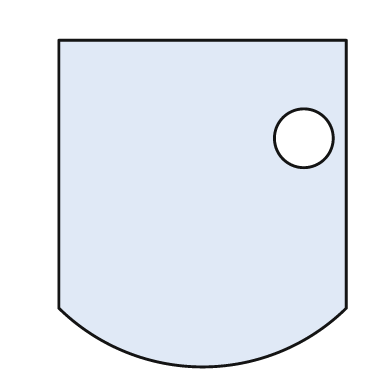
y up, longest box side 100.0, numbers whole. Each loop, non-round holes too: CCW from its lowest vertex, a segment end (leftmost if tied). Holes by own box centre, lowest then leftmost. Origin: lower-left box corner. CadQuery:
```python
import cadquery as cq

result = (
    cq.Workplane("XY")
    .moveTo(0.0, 18.0)
    .threePointArc((44.0, 0.0), (88.0, 18.0))
    .lineTo(88.0, 100.0)
    .lineTo(0.0, 100.0)
    .close()
    .moveTo(75.0, 70.0)
    .circle(9.0)
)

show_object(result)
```